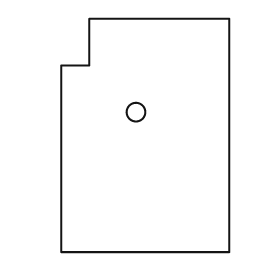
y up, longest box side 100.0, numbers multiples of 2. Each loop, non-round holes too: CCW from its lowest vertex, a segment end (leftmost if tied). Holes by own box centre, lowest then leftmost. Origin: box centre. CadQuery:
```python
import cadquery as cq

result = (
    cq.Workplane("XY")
    .moveTo(-36.0, -50.0)
    .lineTo(36.0, -50.0)
    .lineTo(36.0, 50.0)
    .lineTo(-24.0, 50.0)
    .lineTo(-24.0, 30.0)
    .lineTo(-36.0, 30.0)
    .close()
    .moveTo(-4.0, 10.0)
    .circle(4.0)
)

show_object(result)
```